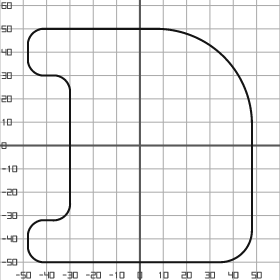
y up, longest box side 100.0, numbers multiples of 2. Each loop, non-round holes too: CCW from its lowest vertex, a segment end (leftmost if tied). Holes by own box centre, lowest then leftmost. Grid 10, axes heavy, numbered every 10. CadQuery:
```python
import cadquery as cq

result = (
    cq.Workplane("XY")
    .moveTo(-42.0, -50.0)
    .lineTo(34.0, -50.0)
    .threePointArc((44.0, -46.0), (48.0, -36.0))
    .lineTo(48.0, 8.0)
    .threePointArc((36.0, 38.0), (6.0, 50.0))
    .lineTo(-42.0, 50.0)
    .threePointArc((-46.0, 48.0), (-48.0, 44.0))
    .lineTo(-48.0, 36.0)
    .threePointArc((-46.0, 32.0), (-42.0, 30.0))
    .lineTo(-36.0, 30.0)
    .threePointArc((-32.0, 28.0), (-30.0, 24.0))
    .lineTo(-30.0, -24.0)
    .threePointArc((-32.0, -30.0), (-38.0, -32.0))
    .lineTo(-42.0, -32.0)
    .threePointArc((-46.0, -34.0), (-48.0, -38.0))
    .lineTo(-48.0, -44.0)
    .threePointArc((-46.0, -48.0), (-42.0, -50.0))
    .close()
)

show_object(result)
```